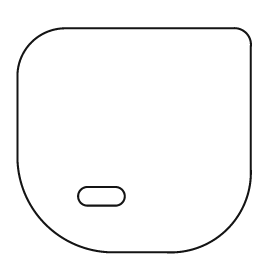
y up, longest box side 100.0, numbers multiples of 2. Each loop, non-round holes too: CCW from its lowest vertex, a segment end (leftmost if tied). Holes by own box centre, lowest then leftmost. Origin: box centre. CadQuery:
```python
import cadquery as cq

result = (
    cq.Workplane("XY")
    .moveTo(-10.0, -48.0)
    .lineTo(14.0, -48.0)
    .threePointArc((40.0, -38.0), (50.0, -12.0))
    .lineTo(50.0, 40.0)
    .threePointArc((48.0, 46.0), (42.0, 48.0))
    .lineTo(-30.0, 48.0)
    .threePointArc((-44.0, 42.0), (-50.0, 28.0))
    .lineTo(-50.0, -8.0)
    .threePointArc((-38.0, -36.0), (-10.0, -48.0))
    .close()
    .moveTo(-20.0, -28.0)
    .lineTo(-8.0, -28.0)
    .threePointArc((-4.0, -24.0), (-8.0, -20.0))
    .lineTo(-20.0, -20.0)
    .threePointArc((-24.0, -24.0), (-20.0, -28.0))
    .close()
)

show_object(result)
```